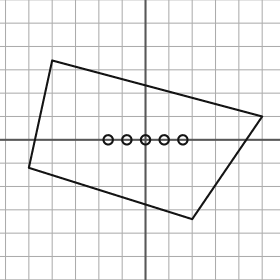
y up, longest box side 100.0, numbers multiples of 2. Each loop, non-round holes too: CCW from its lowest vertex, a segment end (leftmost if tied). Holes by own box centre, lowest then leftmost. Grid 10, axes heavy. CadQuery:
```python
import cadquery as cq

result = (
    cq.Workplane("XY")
    .moveTo(20.0, -34.0)
    .lineTo(50.0, 10.0)
    .lineTo(-40.0, 34.0)
    .lineTo(-50.0, -12.0)
    .close()
    .moveTo(-16.0, 0.0)
    .circle(2.0)
    .moveTo(-8.0, 0.0)
    .circle(2.0)
    .moveTo(0.0, 0.0)
    .circle(2.0)
    .moveTo(8.0, 0.0)
    .circle(2.0)
    .moveTo(16.0, 0.0)
    .circle(2.0)
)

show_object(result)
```